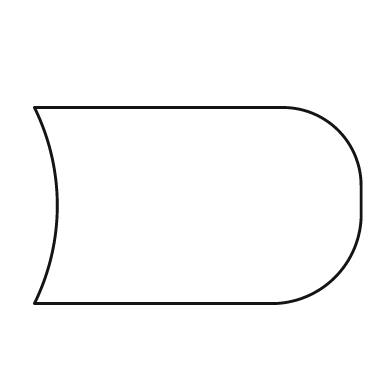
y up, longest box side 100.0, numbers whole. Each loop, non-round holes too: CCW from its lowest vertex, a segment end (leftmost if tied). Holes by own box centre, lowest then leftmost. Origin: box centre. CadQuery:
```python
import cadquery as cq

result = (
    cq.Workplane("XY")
    .moveTo(-50.0, -30.0)
    .lineTo(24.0, -30.0)
    .threePointArc((42.0, -22.0), (50.0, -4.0))
    .lineTo(50.0, 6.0)
    .threePointArc((43.0, 23.0), (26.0, 30.0))
    .lineTo(-50.0, 30.0)
    .threePointArc((-43.0, 0.0), (-50.0, -30.0))
    .close()
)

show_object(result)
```